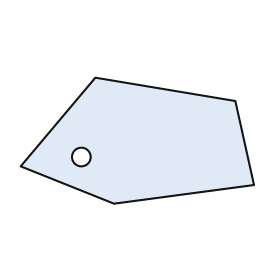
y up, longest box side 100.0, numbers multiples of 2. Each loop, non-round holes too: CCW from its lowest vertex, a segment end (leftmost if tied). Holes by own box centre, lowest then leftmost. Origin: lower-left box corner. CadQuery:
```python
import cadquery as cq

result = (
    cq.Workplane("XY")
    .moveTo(40.0, 0.0)
    .lineTo(100.0, 8.0)
    .lineTo(92.0, 44.0)
    .lineTo(32.0, 54.0)
    .lineTo(0.0, 16.0)
    .close()
    .moveTo(26.0, 20.0)
    .circle(4.0)
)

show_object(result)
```